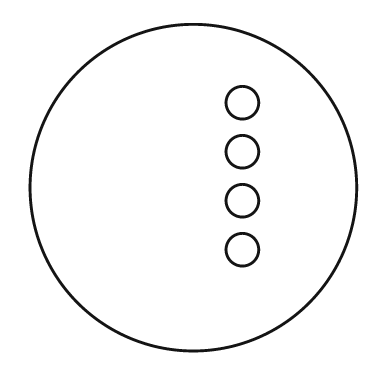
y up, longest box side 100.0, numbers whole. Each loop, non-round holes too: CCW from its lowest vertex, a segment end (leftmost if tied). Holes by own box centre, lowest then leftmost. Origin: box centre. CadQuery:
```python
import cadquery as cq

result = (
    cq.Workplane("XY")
    .moveTo(0.0, 0.0)
    .circle(50.0)
    .moveTo(15.0, -19.0)
    .circle(5.0)
    .moveTo(15.0, -4.0)
    .circle(5.0)
    .moveTo(15.0, 11.0)
    .circle(5.0)
    .moveTo(15.0, 26.0)
    .circle(5.0)
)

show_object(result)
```